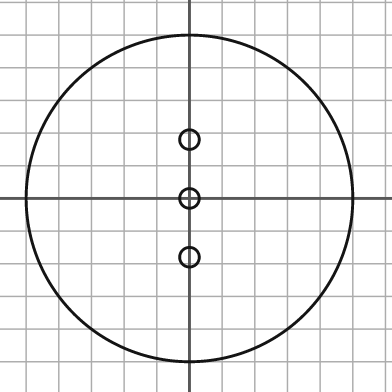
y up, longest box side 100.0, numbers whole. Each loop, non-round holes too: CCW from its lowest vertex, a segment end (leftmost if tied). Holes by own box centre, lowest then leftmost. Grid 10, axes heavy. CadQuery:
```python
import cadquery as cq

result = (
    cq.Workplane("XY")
    .moveTo(0.0, 0.0)
    .circle(50.0)
    .moveTo(0.0, -18.0)
    .circle(3.0)
    .moveTo(0.0, 0.0)
    .circle(3.0)
    .moveTo(0.0, 18.0)
    .circle(3.0)
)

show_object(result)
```